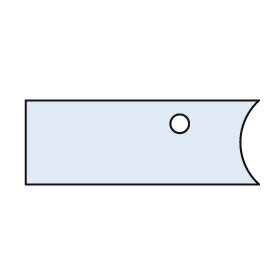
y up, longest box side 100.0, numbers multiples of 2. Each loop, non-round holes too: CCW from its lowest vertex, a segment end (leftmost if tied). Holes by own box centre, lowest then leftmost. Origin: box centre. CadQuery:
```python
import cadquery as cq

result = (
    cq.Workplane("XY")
    .moveTo(-50.0, -18.0)
    .lineTo(50.0, -18.0)
    .threePointArc((42.0, 0.0), (50.0, 18.0))
    .lineTo(-50.0, 18.0)
    .close()
    .moveTo(16.0, 8.0)
    .circle(4.0)
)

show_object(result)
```